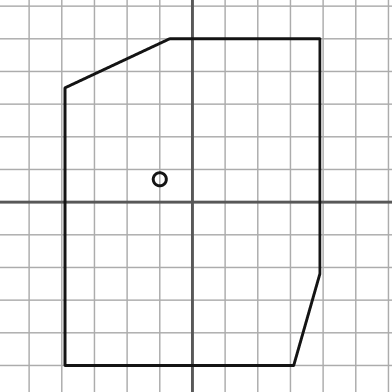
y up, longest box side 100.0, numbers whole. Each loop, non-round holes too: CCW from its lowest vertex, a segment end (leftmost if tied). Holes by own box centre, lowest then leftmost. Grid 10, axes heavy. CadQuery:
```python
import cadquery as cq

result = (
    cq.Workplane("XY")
    .moveTo(-39.0, -50.0)
    .lineTo(31.0, -50.0)
    .lineTo(39.0, -22.0)
    .lineTo(39.0, 50.0)
    .lineTo(-7.0, 50.0)
    .lineTo(-39.0, 35.0)
    .close()
    .moveTo(-10.0, 7.0)
    .circle(2.0)
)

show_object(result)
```